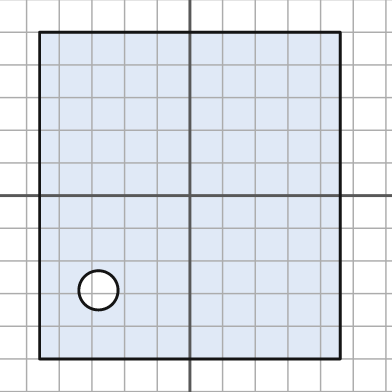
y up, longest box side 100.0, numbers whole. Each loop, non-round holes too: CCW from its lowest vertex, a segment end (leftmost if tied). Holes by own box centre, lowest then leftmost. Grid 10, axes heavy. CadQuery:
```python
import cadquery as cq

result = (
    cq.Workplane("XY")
    .moveTo(-46.0, -50.0)
    .lineTo(46.0, -50.0)
    .lineTo(46.0, 50.0)
    .lineTo(-46.0, 50.0)
    .close()
    .moveTo(-28.0, -29.0)
    .circle(6.0)
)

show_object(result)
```